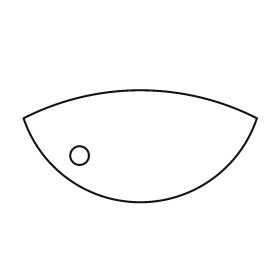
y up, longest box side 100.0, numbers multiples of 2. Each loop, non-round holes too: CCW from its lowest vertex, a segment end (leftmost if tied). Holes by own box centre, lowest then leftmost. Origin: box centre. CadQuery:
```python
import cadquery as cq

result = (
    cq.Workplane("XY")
    .moveTo(-50.0, 12.0)
    .threePointArc((0.0, -24.0), (50.0, 12.0))
    .threePointArc((0.0, 24.0), (-50.0, 12.0))
    .close()
    .moveTo(-26.0, -4.0)
    .circle(4.0)
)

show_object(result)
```